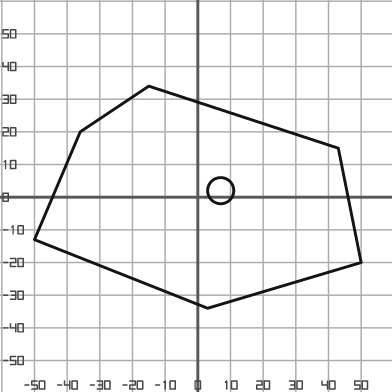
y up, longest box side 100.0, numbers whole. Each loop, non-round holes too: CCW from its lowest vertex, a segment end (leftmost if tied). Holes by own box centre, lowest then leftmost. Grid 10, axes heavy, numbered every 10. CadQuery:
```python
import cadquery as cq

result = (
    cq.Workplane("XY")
    .moveTo(3.0, -34.0)
    .lineTo(50.0, -20.0)
    .lineTo(43.0, 15.0)
    .lineTo(-15.0, 34.0)
    .lineTo(-36.0, 20.0)
    .lineTo(-50.0, -13.0)
    .close()
    .moveTo(7.0, 2.0)
    .circle(4.0)
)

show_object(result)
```